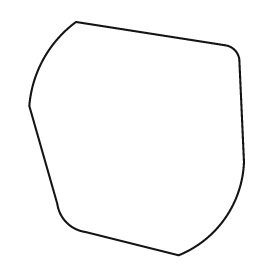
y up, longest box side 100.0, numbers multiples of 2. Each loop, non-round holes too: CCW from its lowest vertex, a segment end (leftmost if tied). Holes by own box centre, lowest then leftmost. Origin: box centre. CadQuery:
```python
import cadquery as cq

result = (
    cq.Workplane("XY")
    .moveTo(18.0, -50.0)
    .threePointArc((38.0, -34.0), (46.0, -10.0))
    .lineTo(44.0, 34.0)
    .threePointArc((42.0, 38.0), (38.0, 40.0))
    .lineTo(-26.0, 50.0)
    .threePointArc((-40.0, 34.0), (-46.0, 14.0))
    .lineTo(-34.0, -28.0)
    .threePointArc((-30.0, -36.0), (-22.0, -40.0))
    .close()
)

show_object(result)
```